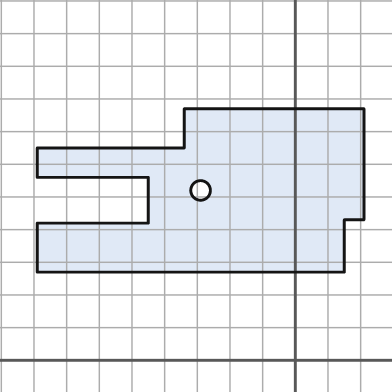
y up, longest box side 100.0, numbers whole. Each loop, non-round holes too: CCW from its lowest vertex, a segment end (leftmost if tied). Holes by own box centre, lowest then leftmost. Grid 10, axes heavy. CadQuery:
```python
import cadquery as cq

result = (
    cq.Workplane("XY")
    .moveTo(-79.0, 27.0)
    .lineTo(15.0, 27.0)
    .lineTo(15.0, 43.0)
    .lineTo(21.0, 43.0)
    .lineTo(21.0, 77.0)
    .lineTo(-34.0, 77.0)
    .lineTo(-34.0, 65.0)
    .lineTo(-79.0, 65.0)
    .lineTo(-79.0, 56.0)
    .lineTo(-45.0, 56.0)
    .lineTo(-45.0, 42.0)
    .lineTo(-79.0, 42.0)
    .close()
    .moveTo(-29.0, 52.0)
    .circle(3.0)
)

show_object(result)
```